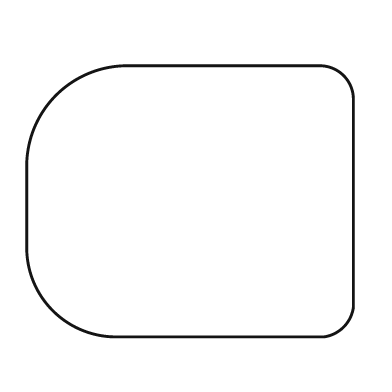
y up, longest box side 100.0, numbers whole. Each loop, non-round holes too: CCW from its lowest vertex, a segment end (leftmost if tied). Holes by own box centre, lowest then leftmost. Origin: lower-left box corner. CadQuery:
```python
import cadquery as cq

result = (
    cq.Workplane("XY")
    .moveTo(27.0, 0.0)
    .lineTo(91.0, 0.0)
    .threePointArc((97.0, 3.0), (100.0, 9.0))
    .lineTo(100.0, 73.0)
    .threePointArc((97.0, 80.0), (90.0, 83.0))
    .lineTo(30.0, 83.0)
    .threePointArc((9.0, 74.0), (0.0, 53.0))
    .lineTo(0.0, 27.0)
    .threePointArc((8.0, 8.0), (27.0, 0.0))
    .close()
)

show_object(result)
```